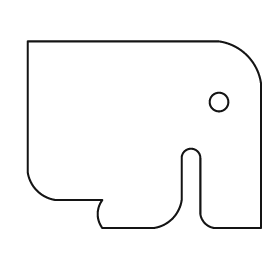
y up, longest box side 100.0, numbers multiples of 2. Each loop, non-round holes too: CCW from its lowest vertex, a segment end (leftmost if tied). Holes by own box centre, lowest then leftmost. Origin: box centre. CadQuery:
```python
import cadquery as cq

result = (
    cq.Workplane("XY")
    .moveTo(-18.0, -40.0)
    .lineTo(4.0, -40.0)
    .threePointArc((12.0, -36.0), (16.0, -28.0))
    .lineTo(16.0, -10.0)
    .threePointArc((20.0, -6.0), (24.0, -10.0))
    .lineTo(24.0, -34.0)
    .threePointArc((26.0, -38.0), (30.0, -40.0))
    .lineTo(50.0, -40.0)
    .lineTo(50.0, 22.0)
    .threePointArc((44.0, 34.0), (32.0, 40.0))
    .lineTo(-50.0, 40.0)
    .lineTo(-50.0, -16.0)
    .threePointArc((-46.0, -24.0), (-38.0, -28.0))
    .lineTo(-18.0, -28.0)
    .threePointArc((-20.0, -34.0), (-18.0, -40.0))
    .close()
    .moveTo(32.0, 14.0)
    .circle(4.0)
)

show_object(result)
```